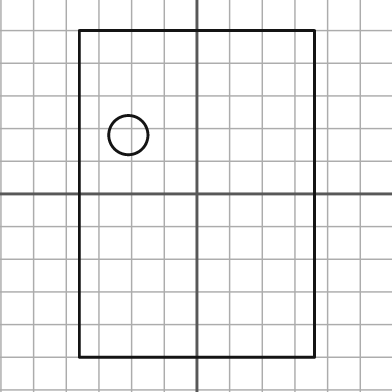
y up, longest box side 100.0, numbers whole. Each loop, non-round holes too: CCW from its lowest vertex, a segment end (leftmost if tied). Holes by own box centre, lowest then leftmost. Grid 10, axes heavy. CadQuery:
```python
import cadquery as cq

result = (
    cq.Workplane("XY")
    .moveTo(-36.0, -50.0)
    .lineTo(36.0, -50.0)
    .lineTo(36.0, 50.0)
    .lineTo(-36.0, 50.0)
    .close()
    .moveTo(-21.0, 18.0)
    .circle(6.0)
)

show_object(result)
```